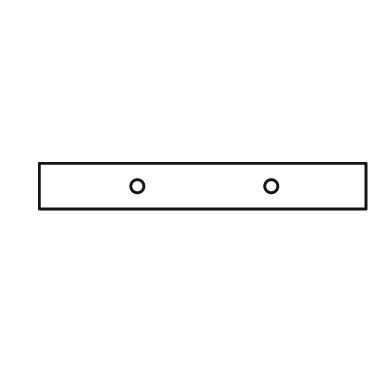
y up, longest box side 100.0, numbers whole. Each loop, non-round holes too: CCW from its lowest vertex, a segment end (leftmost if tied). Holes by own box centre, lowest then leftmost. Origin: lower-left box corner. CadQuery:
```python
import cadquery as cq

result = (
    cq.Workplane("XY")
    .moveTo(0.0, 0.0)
    .lineTo(100.0, 0.0)
    .lineTo(100.0, 14.0)
    .lineTo(0.0, 14.0)
    .close()
    .moveTo(30.0, 7.0)
    .circle(2.0)
    .moveTo(71.0, 7.0)
    .circle(2.0)
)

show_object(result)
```